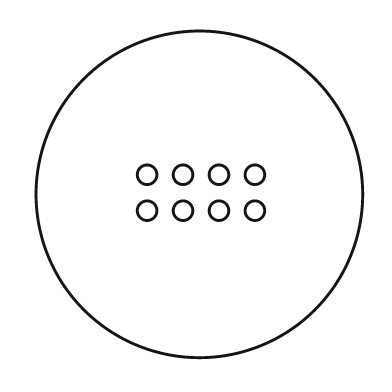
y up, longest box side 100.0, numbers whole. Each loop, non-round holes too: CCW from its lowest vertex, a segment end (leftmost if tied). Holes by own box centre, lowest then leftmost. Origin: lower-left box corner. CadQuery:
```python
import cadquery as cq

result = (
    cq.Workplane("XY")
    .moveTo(50.0, 50.0)
    .circle(50.0)
    .moveTo(34.0, 45.0)
    .circle(3.0)
    .moveTo(45.0, 45.0)
    .circle(3.0)
    .moveTo(56.0, 45.0)
    .circle(3.0)
    .moveTo(67.0, 45.0)
    .circle(3.0)
    .moveTo(34.0, 56.0)
    .circle(3.0)
    .moveTo(45.0, 56.0)
    .circle(3.0)
    .moveTo(56.0, 56.0)
    .circle(3.0)
    .moveTo(67.0, 56.0)
    .circle(3.0)
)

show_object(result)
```